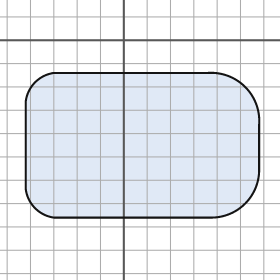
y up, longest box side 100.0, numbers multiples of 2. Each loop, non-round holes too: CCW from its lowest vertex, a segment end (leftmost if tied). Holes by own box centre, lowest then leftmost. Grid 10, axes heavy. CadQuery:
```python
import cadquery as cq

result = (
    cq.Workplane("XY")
    .moveTo(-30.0, -76.0)
    .lineTo(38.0, -76.0)
    .threePointArc((52.0, -70.0), (58.0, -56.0))
    .lineTo(58.0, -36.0)
    .threePointArc((52.0, -20.0), (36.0, -14.0))
    .lineTo(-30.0, -14.0)
    .threePointArc((-38.0, -18.0), (-42.0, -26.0))
    .lineTo(-42.0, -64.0)
    .threePointArc((-38.0, -72.0), (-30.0, -76.0))
    .close()
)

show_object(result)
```